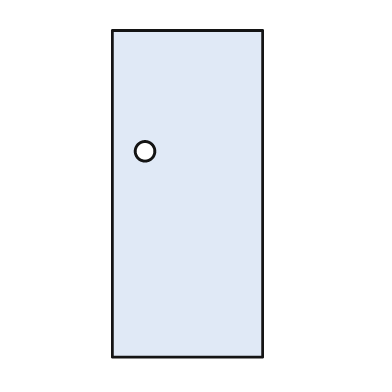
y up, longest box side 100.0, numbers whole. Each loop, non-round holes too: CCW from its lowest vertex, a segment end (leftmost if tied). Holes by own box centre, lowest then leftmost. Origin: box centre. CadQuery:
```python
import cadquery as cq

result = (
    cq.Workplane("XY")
    .moveTo(-23.0, -50.0)
    .lineTo(23.0, -50.0)
    .lineTo(23.0, 50.0)
    .lineTo(-23.0, 50.0)
    .close()
    .moveTo(-13.0, 13.0)
    .circle(3.0)
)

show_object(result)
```